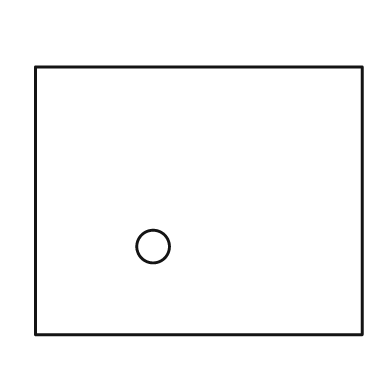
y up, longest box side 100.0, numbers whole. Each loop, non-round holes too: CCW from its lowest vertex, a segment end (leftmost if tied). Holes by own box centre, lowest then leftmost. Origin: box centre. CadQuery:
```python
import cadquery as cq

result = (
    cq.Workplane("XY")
    .moveTo(-50.0, -41.0)
    .lineTo(50.0, -41.0)
    .lineTo(50.0, 41.0)
    .lineTo(-50.0, 41.0)
    .close()
    .moveTo(-14.0, -14.0)
    .circle(5.0)
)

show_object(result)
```